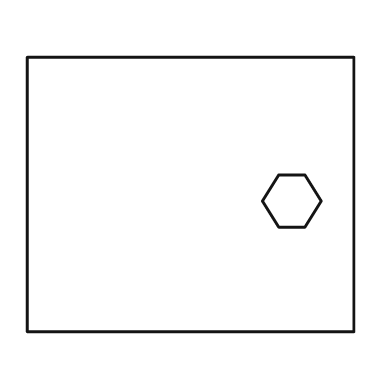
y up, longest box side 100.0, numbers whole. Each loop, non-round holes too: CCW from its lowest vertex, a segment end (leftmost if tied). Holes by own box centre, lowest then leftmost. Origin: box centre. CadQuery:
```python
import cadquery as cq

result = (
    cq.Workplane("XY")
    .moveTo(-50.0, -42.0)
    .lineTo(50.0, -42.0)
    .lineTo(50.0, 42.0)
    .lineTo(-50.0, 42.0)
    .close()
    .moveTo(27.0, -10.0)
    .lineTo(35.0, -10.0)
    .lineTo(40.0, -2.0)
    .lineTo(35.0, 6.0)
    .lineTo(27.0, 6.0)
    .lineTo(22.0, -2.0)
    .close()
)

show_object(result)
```